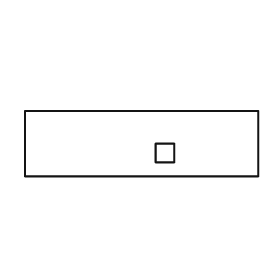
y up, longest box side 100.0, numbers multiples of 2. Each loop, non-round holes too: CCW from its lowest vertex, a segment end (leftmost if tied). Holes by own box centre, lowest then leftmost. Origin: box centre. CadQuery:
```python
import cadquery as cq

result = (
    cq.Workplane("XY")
    .moveTo(-50.0, -14.0)
    .lineTo(50.0, -14.0)
    .lineTo(50.0, 14.0)
    .lineTo(-50.0, 14.0)
    .close()
    .moveTo(6.0, -8.0)
    .lineTo(14.0, -8.0)
    .lineTo(14.0, 0.0)
    .lineTo(6.0, 0.0)
    .close()
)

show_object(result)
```